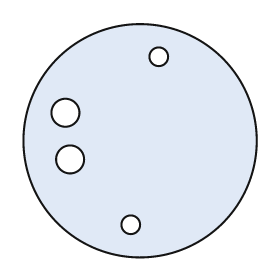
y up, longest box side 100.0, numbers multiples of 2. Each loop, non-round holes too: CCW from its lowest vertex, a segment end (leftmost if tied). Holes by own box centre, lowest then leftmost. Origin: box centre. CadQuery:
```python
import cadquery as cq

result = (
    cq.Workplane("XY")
    .moveTo(0.0, 0.0)
    .circle(50.0)
    .moveTo(-4.0, -36.0)
    .circle(4.0)
    .moveTo(-30.0, -8.0)
    .circle(6.0)
    .moveTo(-32.0, 12.0)
    .circle(6.0)
    .moveTo(8.0, 36.0)
    .circle(4.0)
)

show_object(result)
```